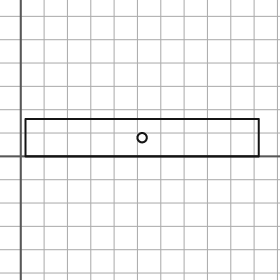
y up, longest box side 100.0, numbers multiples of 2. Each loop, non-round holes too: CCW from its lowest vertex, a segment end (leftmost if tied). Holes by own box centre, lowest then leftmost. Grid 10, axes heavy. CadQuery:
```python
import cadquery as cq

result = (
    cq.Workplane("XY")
    .moveTo(2.0, 0.0)
    .lineTo(102.0, 0.0)
    .lineTo(102.0, 16.0)
    .lineTo(2.0, 16.0)
    .close()
    .moveTo(52.0, 8.0)
    .circle(2.0)
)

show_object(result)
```